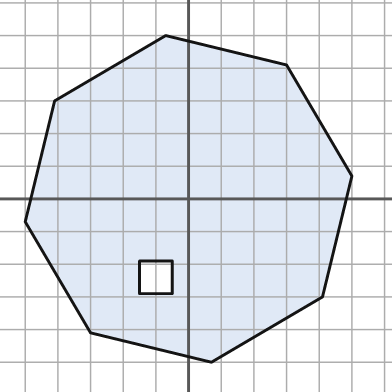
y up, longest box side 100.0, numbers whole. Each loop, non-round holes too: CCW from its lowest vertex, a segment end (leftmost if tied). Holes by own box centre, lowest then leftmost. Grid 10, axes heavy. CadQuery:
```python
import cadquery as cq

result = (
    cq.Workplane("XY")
    .moveTo(7.0, -50.0)
    .lineTo(41.0, -30.0)
    .lineTo(50.0, 7.0)
    .lineTo(30.0, 41.0)
    .lineTo(-7.0, 50.0)
    .lineTo(-41.0, 30.0)
    .lineTo(-50.0, -7.0)
    .lineTo(-30.0, -41.0)
    .close()
    .moveTo(-15.0, -29.0)
    .lineTo(-5.0, -29.0)
    .lineTo(-5.0, -19.0)
    .lineTo(-15.0, -19.0)
    .close()
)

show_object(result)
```